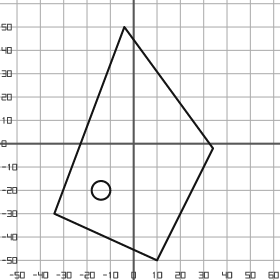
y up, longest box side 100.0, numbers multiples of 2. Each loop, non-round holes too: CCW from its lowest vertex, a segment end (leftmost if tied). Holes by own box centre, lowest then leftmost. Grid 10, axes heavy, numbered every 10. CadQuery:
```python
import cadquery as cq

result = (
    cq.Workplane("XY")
    .moveTo(10.0, -50.0)
    .lineTo(34.0, -2.0)
    .lineTo(-4.0, 50.0)
    .lineTo(-34.0, -30.0)
    .close()
    .moveTo(-14.0, -20.0)
    .circle(4.0)
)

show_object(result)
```